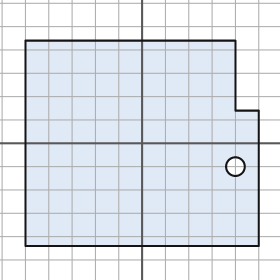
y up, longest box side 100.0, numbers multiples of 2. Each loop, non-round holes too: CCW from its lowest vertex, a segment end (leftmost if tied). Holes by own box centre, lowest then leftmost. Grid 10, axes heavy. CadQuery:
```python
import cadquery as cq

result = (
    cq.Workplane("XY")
    .moveTo(-50.0, -44.0)
    .lineTo(50.0, -44.0)
    .lineTo(50.0, 14.0)
    .lineTo(40.0, 14.0)
    .lineTo(40.0, 44.0)
    .lineTo(-50.0, 44.0)
    .close()
    .moveTo(40.0, -10.0)
    .circle(4.0)
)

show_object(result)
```